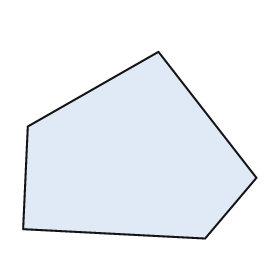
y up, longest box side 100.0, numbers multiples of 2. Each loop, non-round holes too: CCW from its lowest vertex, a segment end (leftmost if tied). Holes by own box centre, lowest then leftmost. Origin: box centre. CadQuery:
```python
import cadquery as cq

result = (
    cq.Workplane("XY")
    .moveTo(28.0, -40.0)
    .lineTo(50.0, -14.0)
    .lineTo(8.0, 40.0)
    .lineTo(-48.0, 8.0)
    .lineTo(-50.0, -36.0)
    .close()
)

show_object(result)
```